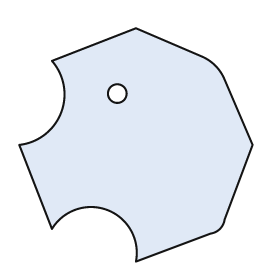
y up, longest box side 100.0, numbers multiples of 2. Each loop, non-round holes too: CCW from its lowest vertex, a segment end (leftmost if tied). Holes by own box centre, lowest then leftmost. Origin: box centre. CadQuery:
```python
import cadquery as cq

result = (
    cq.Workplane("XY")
    .moveTo(0.0, -50.0)
    .lineTo(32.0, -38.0)
    .threePointArc((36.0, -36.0), (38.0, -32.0))
    .lineTo(50.0, 0.0)
    .lineTo(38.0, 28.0)
    .threePointArc((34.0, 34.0), (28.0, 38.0))
    .lineTo(0.0, 50.0)
    .lineTo(-36.0, 36.0)
    .threePointArc((-32.0, 14.0), (-50.0, 0.0))
    .lineTo(-36.0, -36.0)
    .threePointArc((-12.0, -28.0), (0.0, -50.0))
    .close()
    .moveTo(-8.0, 22.0)
    .circle(4.0)
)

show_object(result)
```